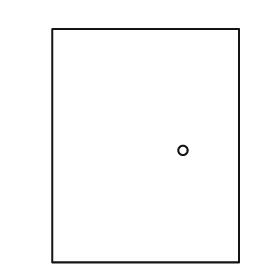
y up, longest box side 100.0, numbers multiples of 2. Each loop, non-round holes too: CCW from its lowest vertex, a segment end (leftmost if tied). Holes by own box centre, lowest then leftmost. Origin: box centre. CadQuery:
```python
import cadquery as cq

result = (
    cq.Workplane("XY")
    .moveTo(-40.0, -50.0)
    .lineTo(40.0, -50.0)
    .lineTo(40.0, 50.0)
    .lineTo(-40.0, 50.0)
    .close()
    .moveTo(16.0, -2.0)
    .circle(2.0)
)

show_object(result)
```